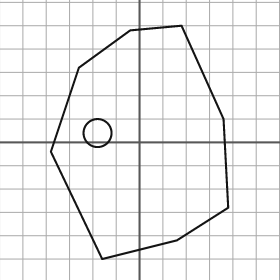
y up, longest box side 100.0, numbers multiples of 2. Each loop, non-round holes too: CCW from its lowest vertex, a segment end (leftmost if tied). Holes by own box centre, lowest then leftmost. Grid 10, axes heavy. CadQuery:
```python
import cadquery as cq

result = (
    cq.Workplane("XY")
    .moveTo(-16.0, -50.0)
    .lineTo(16.0, -42.0)
    .lineTo(38.0, -28.0)
    .lineTo(36.0, 10.0)
    .lineTo(18.0, 50.0)
    .lineTo(-4.0, 48.0)
    .lineTo(-26.0, 32.0)
    .lineTo(-38.0, -4.0)
    .close()
    .moveTo(-18.0, 4.0)
    .circle(6.0)
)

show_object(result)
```